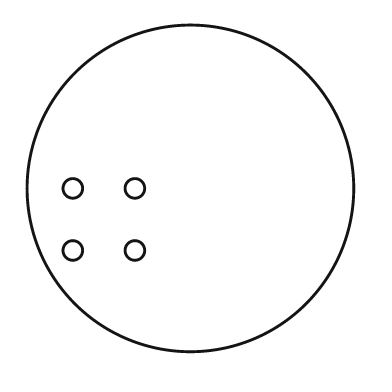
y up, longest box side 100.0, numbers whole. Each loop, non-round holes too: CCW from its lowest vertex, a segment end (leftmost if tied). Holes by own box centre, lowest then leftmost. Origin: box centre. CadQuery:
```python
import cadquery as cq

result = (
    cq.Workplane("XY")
    .moveTo(0.0, 0.0)
    .circle(50.0)
    .moveTo(-36.0, -19.0)
    .circle(3.0)
    .moveTo(-17.0, -19.0)
    .circle(3.0)
    .moveTo(-36.0, 0.0)
    .circle(3.0)
    .moveTo(-17.0, 0.0)
    .circle(3.0)
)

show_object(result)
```